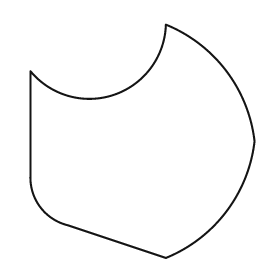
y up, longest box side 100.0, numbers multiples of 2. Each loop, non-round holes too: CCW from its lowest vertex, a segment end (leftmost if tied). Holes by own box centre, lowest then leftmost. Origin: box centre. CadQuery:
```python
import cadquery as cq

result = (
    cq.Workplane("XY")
    .moveTo(10.0, -50.0)
    .threePointArc((36.0, -30.0), (48.0, 0.0))
    .threePointArc((36.0, 30.0), (10.0, 50.0))
    .threePointArc((-12.0, 20.0), (-48.0, 30.0))
    .lineTo(-48.0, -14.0)
    .threePointArc((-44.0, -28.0), (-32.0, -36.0))
    .close()
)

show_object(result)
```